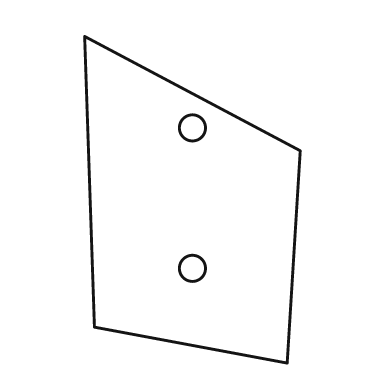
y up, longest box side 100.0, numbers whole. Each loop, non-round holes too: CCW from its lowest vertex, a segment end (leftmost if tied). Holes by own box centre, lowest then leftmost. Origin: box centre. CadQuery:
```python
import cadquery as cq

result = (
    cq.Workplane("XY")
    .moveTo(29.0, -50.0)
    .lineTo(33.0, 15.0)
    .lineTo(-33.0, 50.0)
    .lineTo(-30.0, -39.0)
    .close()
    .moveTo(0.0, -21.0)
    .circle(4.0)
    .moveTo(0.0, 22.0)
    .circle(4.0)
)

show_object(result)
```